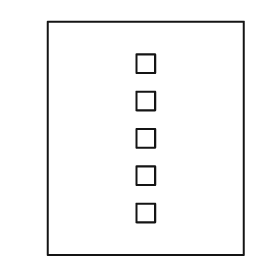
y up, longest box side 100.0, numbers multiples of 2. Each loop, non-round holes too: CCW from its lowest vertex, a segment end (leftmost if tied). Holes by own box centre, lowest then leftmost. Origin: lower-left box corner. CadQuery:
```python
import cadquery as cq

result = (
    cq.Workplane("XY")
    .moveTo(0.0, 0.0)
    .lineTo(84.0, 0.0)
    .lineTo(84.0, 100.0)
    .lineTo(0.0, 100.0)
    .close()
    .moveTo(38.0, 14.0)
    .lineTo(46.0, 14.0)
    .lineTo(46.0, 22.0)
    .lineTo(38.0, 22.0)
    .close()
    .moveTo(38.0, 30.0)
    .lineTo(46.0, 30.0)
    .lineTo(46.0, 38.0)
    .lineTo(38.0, 38.0)
    .close()
    .moveTo(38.0, 46.0)
    .lineTo(46.0, 46.0)
    .lineTo(46.0, 54.0)
    .lineTo(38.0, 54.0)
    .close()
    .moveTo(38.0, 62.0)
    .lineTo(46.0, 62.0)
    .lineTo(46.0, 70.0)
    .lineTo(38.0, 70.0)
    .close()
    .moveTo(38.0, 78.0)
    .lineTo(46.0, 78.0)
    .lineTo(46.0, 86.0)
    .lineTo(38.0, 86.0)
    .close()
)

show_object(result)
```